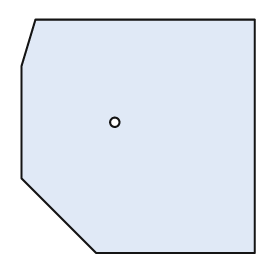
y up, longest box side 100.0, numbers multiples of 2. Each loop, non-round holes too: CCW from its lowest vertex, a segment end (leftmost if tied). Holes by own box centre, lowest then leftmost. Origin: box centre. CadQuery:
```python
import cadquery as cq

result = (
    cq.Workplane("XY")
    .moveTo(-18.0, -50.0)
    .lineTo(50.0, -50.0)
    .lineTo(50.0, 50.0)
    .lineTo(-44.0, 50.0)
    .lineTo(-50.0, 30.0)
    .lineTo(-50.0, -18.0)
    .close()
    .moveTo(-10.0, 6.0)
    .circle(2.0)
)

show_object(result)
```